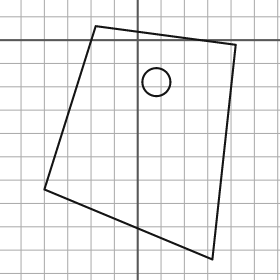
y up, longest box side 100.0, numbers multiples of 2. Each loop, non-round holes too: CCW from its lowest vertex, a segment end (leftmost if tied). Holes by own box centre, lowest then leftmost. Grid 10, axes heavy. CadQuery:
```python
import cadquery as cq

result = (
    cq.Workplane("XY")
    .moveTo(32.0, -94.0)
    .lineTo(42.0, -2.0)
    .lineTo(-18.0, 6.0)
    .lineTo(-40.0, -64.0)
    .close()
    .moveTo(8.0, -18.0)
    .circle(6.0)
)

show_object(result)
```